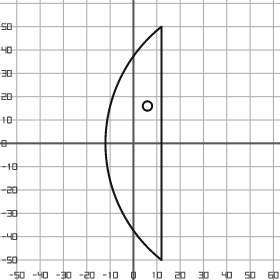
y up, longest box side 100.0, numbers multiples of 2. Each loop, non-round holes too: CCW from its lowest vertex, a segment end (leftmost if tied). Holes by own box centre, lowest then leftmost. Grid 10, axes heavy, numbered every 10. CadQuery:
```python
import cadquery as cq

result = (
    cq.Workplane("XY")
    .moveTo(12.0, -50.0)
    .lineTo(12.0, 50.0)
    .threePointArc((-12.0, 0.0), (12.0, -50.0))
    .close()
    .moveTo(6.0, 16.0)
    .circle(2.0)
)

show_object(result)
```